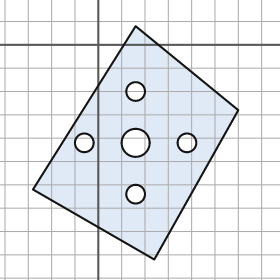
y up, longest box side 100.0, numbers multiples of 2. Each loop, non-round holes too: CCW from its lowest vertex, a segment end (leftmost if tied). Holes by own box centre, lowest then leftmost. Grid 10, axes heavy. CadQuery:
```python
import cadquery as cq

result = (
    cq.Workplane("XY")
    .moveTo(24.0, -92.0)
    .lineTo(60.0, -28.0)
    .lineTo(16.0, 8.0)
    .lineTo(-28.0, -62.0)
    .close()
    .moveTo(16.0, -64.0)
    .circle(4.0)
    .moveTo(-6.0, -42.0)
    .circle(4.0)
    .moveTo(16.0, -42.0)
    .circle(6.0)
    .moveTo(38.0, -42.0)
    .circle(4.0)
    .moveTo(16.0, -20.0)
    .circle(4.0)
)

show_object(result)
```